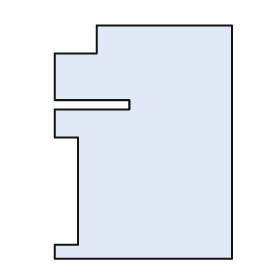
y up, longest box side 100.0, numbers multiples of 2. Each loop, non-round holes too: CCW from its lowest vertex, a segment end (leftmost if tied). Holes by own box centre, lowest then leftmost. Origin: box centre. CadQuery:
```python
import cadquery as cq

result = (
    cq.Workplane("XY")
    .moveTo(-38.0, -50.0)
    .lineTo(38.0, -50.0)
    .lineTo(38.0, 50.0)
    .lineTo(-20.0, 50.0)
    .lineTo(-20.0, 38.0)
    .lineTo(-38.0, 38.0)
    .lineTo(-38.0, 18.0)
    .lineTo(-6.0, 18.0)
    .lineTo(-6.0, 14.0)
    .lineTo(-38.0, 14.0)
    .lineTo(-38.0, 2.0)
    .lineTo(-28.0, 2.0)
    .lineTo(-28.0, -44.0)
    .lineTo(-38.0, -44.0)
    .close()
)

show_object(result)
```